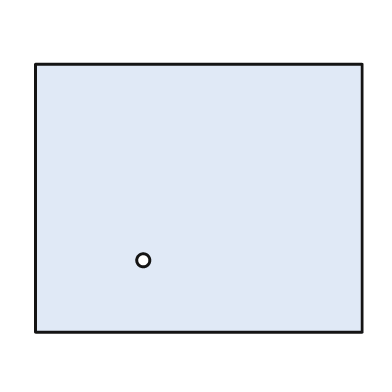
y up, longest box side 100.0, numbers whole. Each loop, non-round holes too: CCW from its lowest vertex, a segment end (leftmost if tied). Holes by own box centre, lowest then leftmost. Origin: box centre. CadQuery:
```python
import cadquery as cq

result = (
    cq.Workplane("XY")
    .moveTo(-50.0, -41.0)
    .lineTo(50.0, -41.0)
    .lineTo(50.0, 41.0)
    .lineTo(-50.0, 41.0)
    .close()
    .moveTo(-17.0, -19.0)
    .circle(2.0)
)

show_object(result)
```